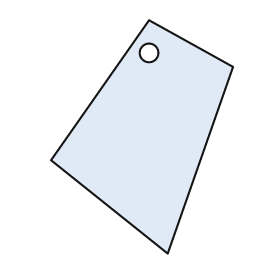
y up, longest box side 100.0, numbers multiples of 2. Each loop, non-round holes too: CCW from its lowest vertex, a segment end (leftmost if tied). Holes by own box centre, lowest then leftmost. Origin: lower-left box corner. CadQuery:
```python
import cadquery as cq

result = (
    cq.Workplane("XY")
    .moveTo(50.0, 0.0)
    .lineTo(78.0, 80.0)
    .lineTo(42.0, 100.0)
    .lineTo(0.0, 40.0)
    .close()
    .moveTo(42.0, 86.0)
    .circle(4.0)
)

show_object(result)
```